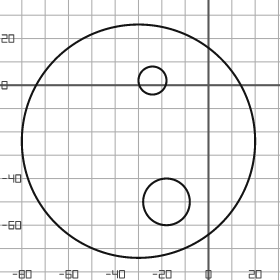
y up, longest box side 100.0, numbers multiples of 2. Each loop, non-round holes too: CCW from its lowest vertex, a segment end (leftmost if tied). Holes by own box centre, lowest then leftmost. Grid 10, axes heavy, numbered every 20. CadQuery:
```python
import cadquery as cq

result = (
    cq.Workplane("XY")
    .moveTo(-30.0, -24.0)
    .circle(50.0)
    .moveTo(-18.0, -50.0)
    .circle(10.0)
    .moveTo(-24.0, 2.0)
    .circle(6.0)
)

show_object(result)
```